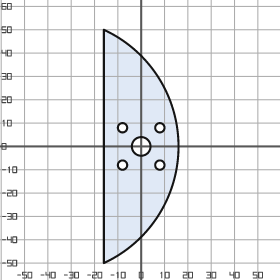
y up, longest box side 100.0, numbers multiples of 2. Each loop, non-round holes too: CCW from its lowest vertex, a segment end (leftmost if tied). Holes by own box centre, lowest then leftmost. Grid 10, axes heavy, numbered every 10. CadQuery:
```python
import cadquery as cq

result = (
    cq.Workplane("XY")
    .moveTo(-16.0, -50.0)
    .threePointArc((16.0, 0.0), (-16.0, 50.0))
    .close()
    .moveTo(-8.0, -8.0)
    .circle(2.0)
    .moveTo(8.0, -8.0)
    .circle(2.0)
    .moveTo(0.0, 0.0)
    .circle(4.0)
    .moveTo(-8.0, 8.0)
    .circle(2.0)
    .moveTo(8.0, 8.0)
    .circle(2.0)
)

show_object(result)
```